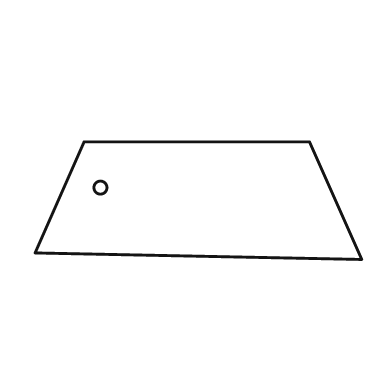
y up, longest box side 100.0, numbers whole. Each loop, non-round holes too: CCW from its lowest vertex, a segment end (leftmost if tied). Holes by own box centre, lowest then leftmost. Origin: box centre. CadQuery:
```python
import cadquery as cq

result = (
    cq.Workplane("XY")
    .moveTo(50.0, -18.0)
    .lineTo(34.0, 18.0)
    .lineTo(-35.0, 18.0)
    .lineTo(-50.0, -16.0)
    .close()
    .moveTo(-30.0, 4.0)
    .circle(2.0)
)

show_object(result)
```